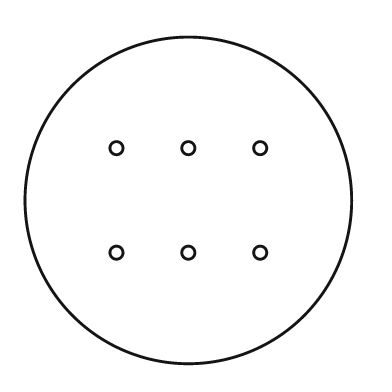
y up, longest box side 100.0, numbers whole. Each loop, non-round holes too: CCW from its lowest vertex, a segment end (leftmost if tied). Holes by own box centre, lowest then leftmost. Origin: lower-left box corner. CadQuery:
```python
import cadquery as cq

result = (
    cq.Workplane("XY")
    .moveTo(50.0, 50.0)
    .circle(50.0)
    .moveTo(28.0, 34.0)
    .circle(2.0)
    .moveTo(50.0, 34.0)
    .circle(2.0)
    .moveTo(72.0, 34.0)
    .circle(2.0)
    .moveTo(28.0, 66.0)
    .circle(2.0)
    .moveTo(50.0, 66.0)
    .circle(2.0)
    .moveTo(72.0, 66.0)
    .circle(2.0)
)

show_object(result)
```